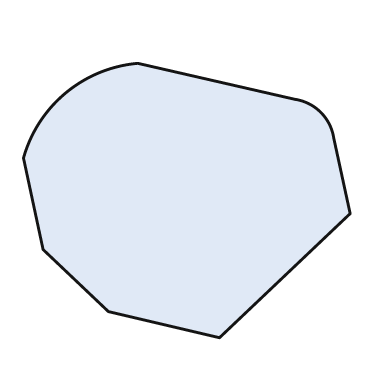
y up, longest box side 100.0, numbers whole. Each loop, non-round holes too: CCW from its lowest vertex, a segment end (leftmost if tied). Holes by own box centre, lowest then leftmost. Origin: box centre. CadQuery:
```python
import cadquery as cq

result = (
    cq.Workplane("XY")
    .moveTo(10.0, -42.0)
    .lineTo(50.0, -4.0)
    .lineTo(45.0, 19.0)
    .threePointArc((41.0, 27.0), (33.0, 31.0))
    .lineTo(-15.0, 42.0)
    .threePointArc((-37.0, 33.0), (-50.0, 13.0))
    .lineTo(-44.0, -15.0)
    .lineTo(-24.0, -34.0)
    .close()
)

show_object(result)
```